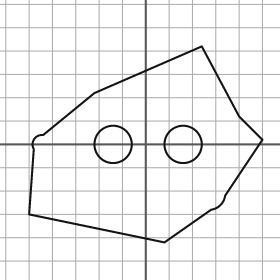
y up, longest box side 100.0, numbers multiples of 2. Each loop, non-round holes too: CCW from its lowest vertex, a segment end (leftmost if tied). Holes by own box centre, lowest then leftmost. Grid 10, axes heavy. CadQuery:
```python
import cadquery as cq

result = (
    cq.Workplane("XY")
    .moveTo(8.0, -42.0)
    .lineTo(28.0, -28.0)
    .threePointArc((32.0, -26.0), (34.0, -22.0))
    .lineTo(50.0, 2.0)
    .lineTo(40.0, 12.0)
    .lineTo(24.0, 42.0)
    .lineTo(-22.0, 22.0)
    .lineTo(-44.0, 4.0)
    .threePointArc((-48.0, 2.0), (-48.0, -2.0))
    .lineTo(-50.0, -30.0)
    .close()
    .moveTo(-14.0, 0.0)
    .circle(8.0)
    .moveTo(16.0, 0.0)
    .circle(8.0)
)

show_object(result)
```